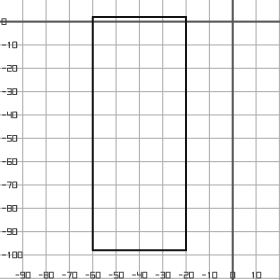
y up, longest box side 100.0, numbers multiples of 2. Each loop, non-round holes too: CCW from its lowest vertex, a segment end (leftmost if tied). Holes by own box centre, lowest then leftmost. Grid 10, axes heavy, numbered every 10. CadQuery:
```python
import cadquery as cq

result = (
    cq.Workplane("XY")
    .moveTo(-60.0, -98.0)
    .lineTo(-20.0, -98.0)
    .lineTo(-20.0, 2.0)
    .lineTo(-60.0, 2.0)
    .close()
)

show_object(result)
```